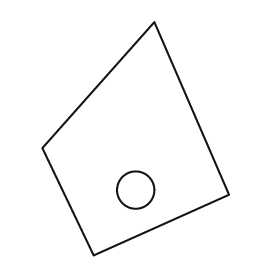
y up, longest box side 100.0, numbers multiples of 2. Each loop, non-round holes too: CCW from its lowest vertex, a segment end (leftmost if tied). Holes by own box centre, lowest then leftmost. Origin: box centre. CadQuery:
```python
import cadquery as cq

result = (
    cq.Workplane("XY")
    .moveTo(-18.0, -50.0)
    .lineTo(40.0, -24.0)
    .lineTo(8.0, 50.0)
    .lineTo(-40.0, -4.0)
    .close()
    .moveTo(0.0, -22.0)
    .circle(8.0)
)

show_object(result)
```